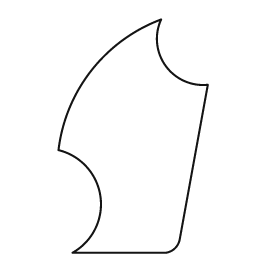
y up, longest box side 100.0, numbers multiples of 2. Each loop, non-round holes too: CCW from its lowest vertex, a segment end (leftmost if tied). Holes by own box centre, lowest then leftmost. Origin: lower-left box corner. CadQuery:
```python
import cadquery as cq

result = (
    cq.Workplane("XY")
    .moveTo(6.0, 0.0)
    .lineTo(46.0, 0.0)
    .threePointArc((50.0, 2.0), (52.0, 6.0))
    .lineTo(64.0, 72.0)
    .threePointArc((46.0, 80.0), (44.0, 100.0))
    .threePointArc((14.0, 78.0), (0.0, 44.0))
    .threePointArc((18.0, 24.0), (6.0, 0.0))
    .close()
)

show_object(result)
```